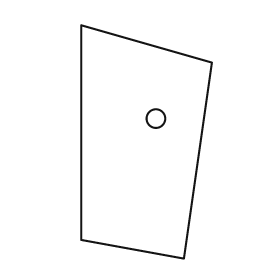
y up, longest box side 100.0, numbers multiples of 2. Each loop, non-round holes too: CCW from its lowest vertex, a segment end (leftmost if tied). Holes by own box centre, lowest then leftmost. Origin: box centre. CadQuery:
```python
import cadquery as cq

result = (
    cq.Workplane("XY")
    .moveTo(16.0, -50.0)
    .lineTo(28.0, 34.0)
    .lineTo(-28.0, 50.0)
    .lineTo(-28.0, -42.0)
    .close()
    .moveTo(4.0, 10.0)
    .circle(4.0)
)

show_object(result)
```